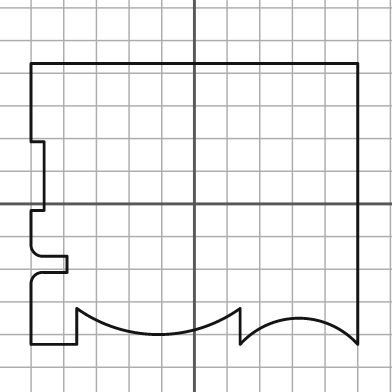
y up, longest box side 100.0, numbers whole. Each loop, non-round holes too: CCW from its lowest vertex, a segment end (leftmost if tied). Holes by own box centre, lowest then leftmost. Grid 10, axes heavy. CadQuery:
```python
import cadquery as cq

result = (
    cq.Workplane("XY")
    .moveTo(-50.0, -43.0)
    .lineTo(-36.0, -43.0)
    .lineTo(-36.0, -32.0)
    .threePointArc((-11.0, -40.0), (14.0, -32.0))
    .lineTo(14.0, -43.0)
    .threePointArc((32.0, -35.0), (50.0, -43.0))
    .lineTo(50.0, 43.0)
    .lineTo(-50.0, 43.0)
    .lineTo(-50.0, 19.0)
    .lineTo(-46.0, 19.0)
    .lineTo(-46.0, -2.0)
    .lineTo(-50.0, -2.0)
    .lineTo(-50.0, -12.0)
    .threePointArc((-49.0, -15.0), (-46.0, -16.0))
    .lineTo(-39.0, -16.0)
    .lineTo(-39.0, -21.0)
    .lineTo(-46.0, -21.0)
    .threePointArc((-49.0, -22.0), (-50.0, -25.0))
    .close()
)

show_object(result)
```